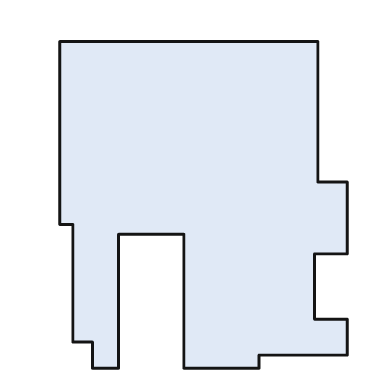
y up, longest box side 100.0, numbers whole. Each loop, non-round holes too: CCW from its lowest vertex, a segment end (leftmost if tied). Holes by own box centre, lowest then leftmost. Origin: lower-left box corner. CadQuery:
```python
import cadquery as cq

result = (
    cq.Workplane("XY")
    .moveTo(10.0, 0.0)
    .lineTo(18.0, 0.0)
    .lineTo(18.0, 41.0)
    .lineTo(38.0, 41.0)
    .lineTo(38.0, 0.0)
    .lineTo(61.0, 0.0)
    .lineTo(61.0, 4.0)
    .lineTo(88.0, 4.0)
    .lineTo(88.0, 15.0)
    .lineTo(78.0, 15.0)
    .lineTo(78.0, 35.0)
    .lineTo(88.0, 35.0)
    .lineTo(88.0, 57.0)
    .lineTo(79.0, 57.0)
    .lineTo(79.0, 100.0)
    .lineTo(0.0, 100.0)
    .lineTo(0.0, 44.0)
    .lineTo(4.0, 44.0)
    .lineTo(4.0, 8.0)
    .lineTo(10.0, 8.0)
    .close()
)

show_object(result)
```